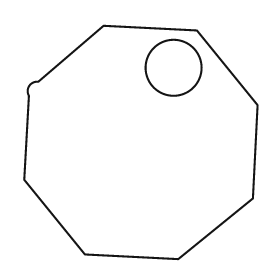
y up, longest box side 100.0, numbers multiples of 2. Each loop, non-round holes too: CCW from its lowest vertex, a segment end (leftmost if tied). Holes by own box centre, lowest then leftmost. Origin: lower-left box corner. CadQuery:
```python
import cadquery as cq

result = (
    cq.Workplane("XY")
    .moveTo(66.0, 0.0)
    .lineTo(98.0, 26.0)
    .lineTo(100.0, 66.0)
    .lineTo(74.0, 98.0)
    .lineTo(34.0, 100.0)
    .lineTo(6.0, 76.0)
    .threePointArc((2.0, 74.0), (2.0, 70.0))
    .lineTo(0.0, 34.0)
    .lineTo(26.0, 2.0)
    .close()
    .moveTo(64.0, 82.0)
    .circle(12.0)
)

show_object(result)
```